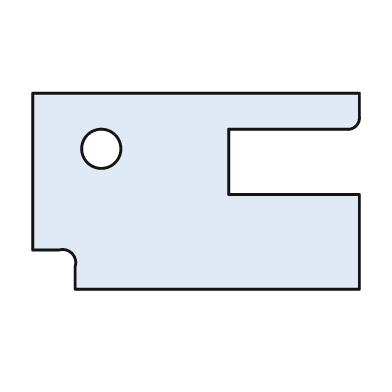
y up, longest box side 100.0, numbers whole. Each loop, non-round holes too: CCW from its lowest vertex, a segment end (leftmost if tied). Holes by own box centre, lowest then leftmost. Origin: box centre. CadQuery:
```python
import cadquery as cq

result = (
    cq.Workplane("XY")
    .moveTo(-37.0, -30.0)
    .lineTo(50.0, -30.0)
    .lineTo(50.0, -1.0)
    .lineTo(10.0, -1.0)
    .lineTo(10.0, 19.0)
    .lineTo(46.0, 19.0)
    .threePointArc((49.0, 20.0), (50.0, 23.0))
    .lineTo(50.0, 30.0)
    .lineTo(-50.0, 30.0)
    .lineTo(-50.0, -18.0)
    .lineTo(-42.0, -18.0)
    .threePointArc((-38.0, -19.0), (-37.0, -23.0))
    .close()
    .moveTo(-29.0, 13.0)
    .circle(6.0)
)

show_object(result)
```